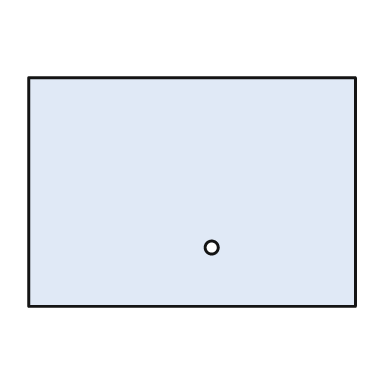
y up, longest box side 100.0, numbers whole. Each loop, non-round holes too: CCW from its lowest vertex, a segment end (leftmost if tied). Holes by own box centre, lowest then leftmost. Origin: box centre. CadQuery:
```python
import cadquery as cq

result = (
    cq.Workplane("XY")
    .moveTo(-50.0, -35.0)
    .lineTo(50.0, -35.0)
    .lineTo(50.0, 35.0)
    .lineTo(-50.0, 35.0)
    .close()
    .moveTo(6.0, -17.0)
    .circle(2.0)
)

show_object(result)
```